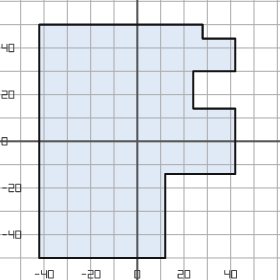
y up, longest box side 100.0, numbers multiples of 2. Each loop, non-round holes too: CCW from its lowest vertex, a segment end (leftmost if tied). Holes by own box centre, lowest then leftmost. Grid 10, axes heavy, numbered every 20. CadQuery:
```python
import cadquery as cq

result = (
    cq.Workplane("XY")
    .moveTo(-42.0, -50.0)
    .lineTo(12.0, -50.0)
    .lineTo(12.0, -14.0)
    .lineTo(42.0, -14.0)
    .lineTo(42.0, 14.0)
    .lineTo(24.0, 14.0)
    .lineTo(24.0, 30.0)
    .lineTo(42.0, 30.0)
    .lineTo(42.0, 44.0)
    .lineTo(28.0, 44.0)
    .lineTo(28.0, 50.0)
    .lineTo(-42.0, 50.0)
    .close()
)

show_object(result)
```